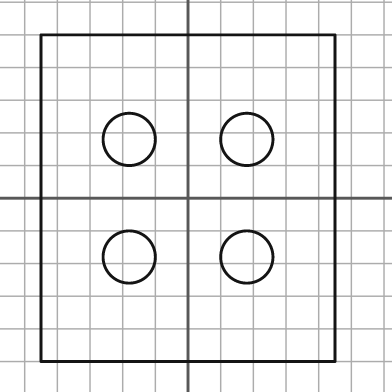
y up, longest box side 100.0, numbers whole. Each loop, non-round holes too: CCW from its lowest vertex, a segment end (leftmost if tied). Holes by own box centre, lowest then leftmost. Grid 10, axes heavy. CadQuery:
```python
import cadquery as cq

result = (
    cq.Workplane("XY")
    .moveTo(-45.0, -50.0)
    .lineTo(45.0, -50.0)
    .lineTo(45.0, 50.0)
    .lineTo(-45.0, 50.0)
    .close()
    .moveTo(-18.0, -18.0)
    .circle(8.0)
    .moveTo(18.0, -18.0)
    .circle(8.0)
    .moveTo(-18.0, 18.0)
    .circle(8.0)
    .moveTo(18.0, 18.0)
    .circle(8.0)
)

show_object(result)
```